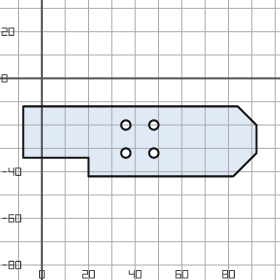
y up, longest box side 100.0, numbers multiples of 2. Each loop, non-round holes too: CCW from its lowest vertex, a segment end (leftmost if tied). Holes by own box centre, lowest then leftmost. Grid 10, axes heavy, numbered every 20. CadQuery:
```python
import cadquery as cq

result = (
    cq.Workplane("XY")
    .moveTo(20.0, -42.0)
    .lineTo(82.0, -42.0)
    .lineTo(92.0, -32.0)
    .lineTo(92.0, -20.0)
    .lineTo(84.0, -12.0)
    .lineTo(-8.0, -12.0)
    .lineTo(-8.0, -34.0)
    .lineTo(20.0, -34.0)
    .close()
    .moveTo(36.0, -32.0)
    .circle(2.0)
    .moveTo(48.0, -32.0)
    .circle(2.0)
    .moveTo(36.0, -20.0)
    .circle(2.0)
    .moveTo(48.0, -20.0)
    .circle(2.0)
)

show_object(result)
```